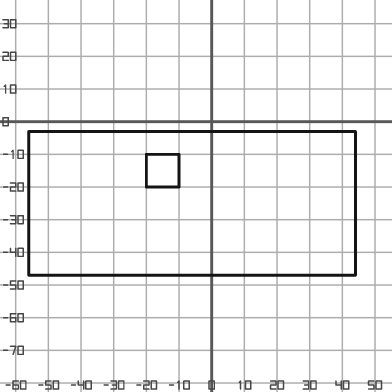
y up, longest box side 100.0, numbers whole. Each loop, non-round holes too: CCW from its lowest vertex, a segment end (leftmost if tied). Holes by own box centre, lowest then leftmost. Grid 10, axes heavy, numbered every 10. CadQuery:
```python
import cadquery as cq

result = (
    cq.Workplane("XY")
    .moveTo(-56.0, -47.0)
    .lineTo(44.0, -47.0)
    .lineTo(44.0, -3.0)
    .lineTo(-56.0, -3.0)
    .close()
    .moveTo(-20.0, -20.0)
    .lineTo(-10.0, -20.0)
    .lineTo(-10.0, -10.0)
    .lineTo(-20.0, -10.0)
    .close()
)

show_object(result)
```